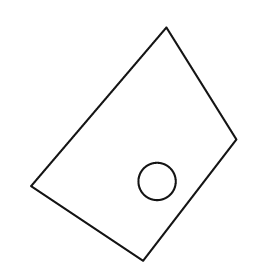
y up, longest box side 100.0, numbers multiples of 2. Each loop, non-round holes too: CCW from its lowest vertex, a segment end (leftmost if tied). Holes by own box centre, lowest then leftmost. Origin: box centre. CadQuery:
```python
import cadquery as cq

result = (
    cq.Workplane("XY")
    .moveTo(4.0, -50.0)
    .lineTo(44.0, 2.0)
    .lineTo(14.0, 50.0)
    .lineTo(-44.0, -18.0)
    .close()
    .moveTo(10.0, -16.0)
    .circle(8.0)
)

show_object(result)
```